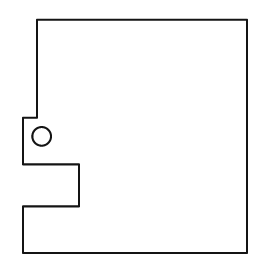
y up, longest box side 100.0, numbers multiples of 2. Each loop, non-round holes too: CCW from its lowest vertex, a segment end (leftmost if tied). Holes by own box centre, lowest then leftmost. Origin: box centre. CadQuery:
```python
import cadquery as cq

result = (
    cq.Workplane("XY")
    .moveTo(-48.0, -50.0)
    .lineTo(48.0, -50.0)
    .lineTo(48.0, 50.0)
    .lineTo(-42.0, 50.0)
    .lineTo(-42.0, 8.0)
    .lineTo(-48.0, 8.0)
    .lineTo(-48.0, -12.0)
    .lineTo(-24.0, -12.0)
    .lineTo(-24.0, -30.0)
    .lineTo(-48.0, -30.0)
    .close()
    .moveTo(-40.0, 0.0)
    .circle(4.0)
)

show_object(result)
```